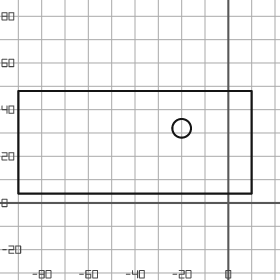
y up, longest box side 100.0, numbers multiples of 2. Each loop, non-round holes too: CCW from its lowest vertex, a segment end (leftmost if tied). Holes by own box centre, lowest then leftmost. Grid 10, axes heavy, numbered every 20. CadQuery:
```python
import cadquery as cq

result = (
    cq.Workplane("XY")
    .moveTo(-90.0, 4.0)
    .lineTo(10.0, 4.0)
    .lineTo(10.0, 48.0)
    .lineTo(-90.0, 48.0)
    .close()
    .moveTo(-20.0, 32.0)
    .circle(4.0)
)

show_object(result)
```